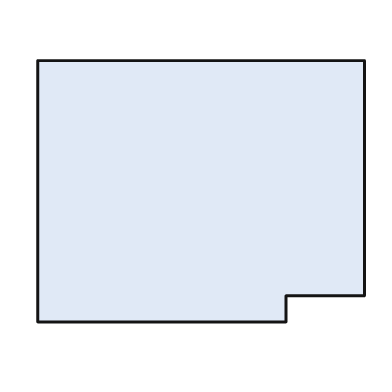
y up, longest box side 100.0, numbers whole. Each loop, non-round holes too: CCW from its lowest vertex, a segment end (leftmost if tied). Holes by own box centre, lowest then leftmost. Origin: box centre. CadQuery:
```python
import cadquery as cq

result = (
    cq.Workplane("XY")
    .moveTo(-50.0, -40.0)
    .lineTo(26.0, -40.0)
    .lineTo(26.0, -32.0)
    .lineTo(50.0, -32.0)
    .lineTo(50.0, 40.0)
    .lineTo(-50.0, 40.0)
    .close()
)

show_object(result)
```